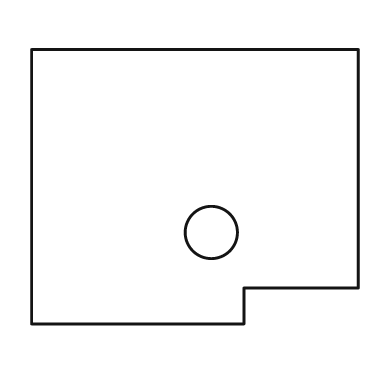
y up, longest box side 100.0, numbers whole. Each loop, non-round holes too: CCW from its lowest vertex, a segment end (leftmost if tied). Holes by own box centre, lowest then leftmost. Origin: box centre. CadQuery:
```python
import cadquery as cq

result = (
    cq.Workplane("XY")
    .moveTo(-50.0, -42.0)
    .lineTo(15.0, -42.0)
    .lineTo(15.0, -31.0)
    .lineTo(50.0, -31.0)
    .lineTo(50.0, 42.0)
    .lineTo(-50.0, 42.0)
    .close()
    .moveTo(5.0, -14.0)
    .circle(8.0)
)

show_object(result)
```